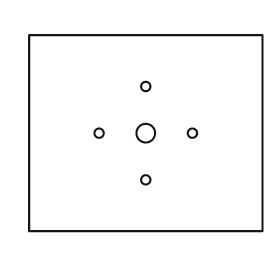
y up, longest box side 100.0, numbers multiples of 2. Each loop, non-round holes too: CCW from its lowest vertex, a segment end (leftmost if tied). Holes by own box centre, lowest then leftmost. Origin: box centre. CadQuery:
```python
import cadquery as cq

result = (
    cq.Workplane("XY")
    .moveTo(-50.0, -42.0)
    .lineTo(50.0, -42.0)
    .lineTo(50.0, 42.0)
    .lineTo(-50.0, 42.0)
    .close()
    .moveTo(0.0, -20.0)
    .circle(2.0)
    .moveTo(-20.0, 0.0)
    .circle(2.0)
    .moveTo(0.0, 0.0)
    .circle(4.0)
    .moveTo(20.0, 0.0)
    .circle(2.0)
    .moveTo(0.0, 20.0)
    .circle(2.0)
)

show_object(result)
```